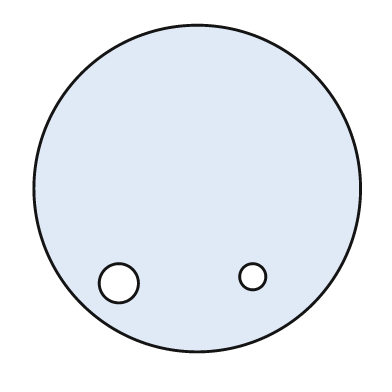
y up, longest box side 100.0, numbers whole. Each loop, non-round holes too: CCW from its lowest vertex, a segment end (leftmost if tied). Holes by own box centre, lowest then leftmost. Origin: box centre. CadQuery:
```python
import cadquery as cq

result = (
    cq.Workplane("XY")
    .moveTo(0.0, 0.0)
    .circle(50.0)
    .moveTo(-24.0, -29.0)
    .circle(6.0)
    .moveTo(17.0, -27.0)
    .circle(4.0)
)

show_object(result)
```